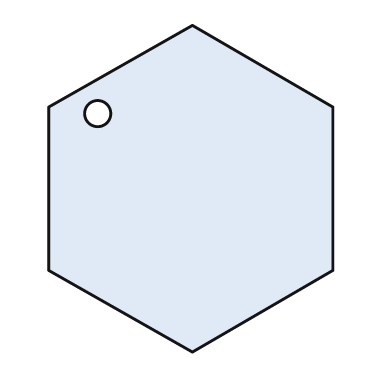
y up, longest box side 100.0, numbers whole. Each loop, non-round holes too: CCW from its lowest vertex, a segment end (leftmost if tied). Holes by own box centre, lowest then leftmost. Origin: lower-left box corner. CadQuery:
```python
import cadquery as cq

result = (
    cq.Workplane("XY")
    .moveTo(44.0, 0.0)
    .lineTo(87.0, 25.0)
    .lineTo(87.0, 75.0)
    .lineTo(44.0, 100.0)
    .lineTo(0.0, 75.0)
    .lineTo(0.0, 25.0)
    .close()
    .moveTo(15.0, 73.0)
    .circle(4.0)
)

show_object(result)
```